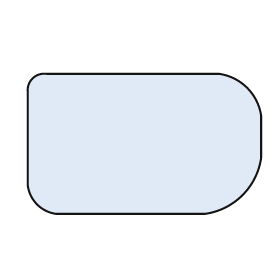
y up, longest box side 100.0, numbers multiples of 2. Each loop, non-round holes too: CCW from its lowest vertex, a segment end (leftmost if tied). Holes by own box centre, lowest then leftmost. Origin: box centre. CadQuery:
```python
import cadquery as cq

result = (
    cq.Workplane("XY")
    .moveTo(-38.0, -30.0)
    .lineTo(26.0, -30.0)
    .threePointArc((42.0, -22.0), (50.0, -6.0))
    .lineTo(50.0, 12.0)
    .threePointArc((44.0, 24.0), (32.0, 30.0))
    .lineTo(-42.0, 30.0)
    .threePointArc((-48.0, 28.0), (-50.0, 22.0))
    .lineTo(-50.0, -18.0)
    .threePointArc((-46.0, -26.0), (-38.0, -30.0))
    .close()
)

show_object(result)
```